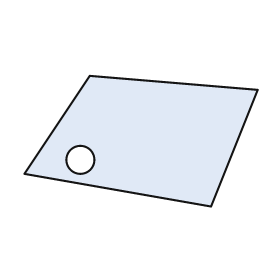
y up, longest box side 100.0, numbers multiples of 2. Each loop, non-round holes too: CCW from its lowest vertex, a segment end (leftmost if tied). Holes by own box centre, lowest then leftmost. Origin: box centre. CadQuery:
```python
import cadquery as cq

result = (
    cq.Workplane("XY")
    .moveTo(30.0, -28.0)
    .lineTo(50.0, 22.0)
    .lineTo(-22.0, 28.0)
    .lineTo(-50.0, -14.0)
    .close()
    .moveTo(-26.0, -8.0)
    .circle(6.0)
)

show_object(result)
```